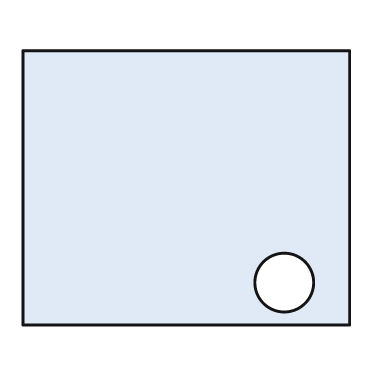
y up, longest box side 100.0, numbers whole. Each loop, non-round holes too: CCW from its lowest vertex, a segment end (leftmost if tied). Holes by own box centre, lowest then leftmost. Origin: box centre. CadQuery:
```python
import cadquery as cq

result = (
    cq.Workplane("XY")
    .moveTo(-50.0, -42.0)
    .lineTo(50.0, -42.0)
    .lineTo(50.0, 42.0)
    .lineTo(-50.0, 42.0)
    .close()
    .moveTo(30.0, -29.0)
    .circle(9.0)
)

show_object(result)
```